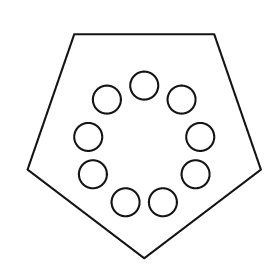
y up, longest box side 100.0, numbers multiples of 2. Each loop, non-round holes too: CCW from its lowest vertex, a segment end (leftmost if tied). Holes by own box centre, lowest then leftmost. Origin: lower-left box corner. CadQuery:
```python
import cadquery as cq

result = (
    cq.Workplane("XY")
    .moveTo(50.0, 0.0)
    .lineTo(100.0, 38.0)
    .lineTo(80.0, 96.0)
    .lineTo(20.0, 96.0)
    .lineTo(0.0, 38.0)
    .close()
    .moveTo(42.0, 24.0)
    .circle(6.0)
    .moveTo(58.0, 24.0)
    .circle(6.0)
    .moveTo(28.0, 36.0)
    .circle(6.0)
    .moveTo(72.0, 36.0)
    .circle(6.0)
    .moveTo(26.0, 52.0)
    .circle(6.0)
    .moveTo(74.0, 52.0)
    .circle(6.0)
    .moveTo(34.0, 68.0)
    .circle(6.0)
    .moveTo(66.0, 68.0)
    .circle(6.0)
    .moveTo(50.0, 74.0)
    .circle(6.0)
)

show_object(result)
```